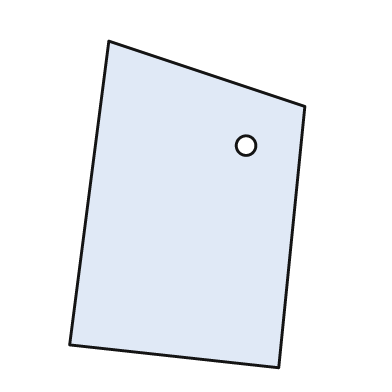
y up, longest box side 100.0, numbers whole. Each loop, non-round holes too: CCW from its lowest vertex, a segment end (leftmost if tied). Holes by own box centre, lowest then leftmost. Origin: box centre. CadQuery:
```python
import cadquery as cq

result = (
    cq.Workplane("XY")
    .moveTo(28.0, -50.0)
    .lineTo(36.0, 30.0)
    .lineTo(-24.0, 50.0)
    .lineTo(-36.0, -43.0)
    .close()
    .moveTo(18.0, 18.0)
    .circle(3.0)
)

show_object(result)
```